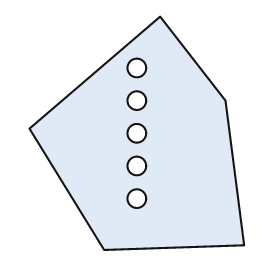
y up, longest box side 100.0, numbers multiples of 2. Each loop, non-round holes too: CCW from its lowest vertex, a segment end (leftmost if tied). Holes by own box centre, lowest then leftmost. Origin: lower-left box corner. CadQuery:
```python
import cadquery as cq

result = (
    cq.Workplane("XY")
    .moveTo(32.0, 0.0)
    .lineTo(92.0, 2.0)
    .lineTo(84.0, 64.0)
    .lineTo(56.0, 100.0)
    .lineTo(0.0, 52.0)
    .close()
    .moveTo(46.0, 22.0)
    .circle(4.0)
    .moveTo(46.0, 36.0)
    .circle(4.0)
    .moveTo(46.0, 50.0)
    .circle(4.0)
    .moveTo(46.0, 64.0)
    .circle(4.0)
    .moveTo(46.0, 78.0)
    .circle(4.0)
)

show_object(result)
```